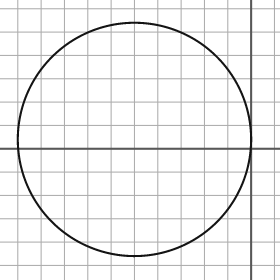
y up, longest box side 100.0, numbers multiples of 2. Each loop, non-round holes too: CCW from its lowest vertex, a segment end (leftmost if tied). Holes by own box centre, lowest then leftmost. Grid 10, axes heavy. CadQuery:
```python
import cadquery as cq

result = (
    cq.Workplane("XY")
    .moveTo(-50.0, 4.0)
    .circle(50.0)
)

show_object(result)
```